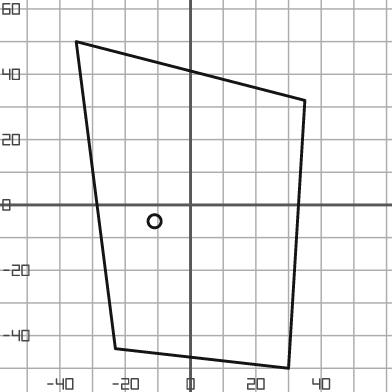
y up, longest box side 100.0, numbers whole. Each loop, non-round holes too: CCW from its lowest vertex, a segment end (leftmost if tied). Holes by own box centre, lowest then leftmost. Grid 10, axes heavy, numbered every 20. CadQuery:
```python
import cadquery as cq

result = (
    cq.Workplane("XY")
    .moveTo(30.0, -50.0)
    .lineTo(35.0, 32.0)
    .lineTo(-35.0, 50.0)
    .lineTo(-23.0, -44.0)
    .close()
    .moveTo(-11.0, -5.0)
    .circle(2.0)
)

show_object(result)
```